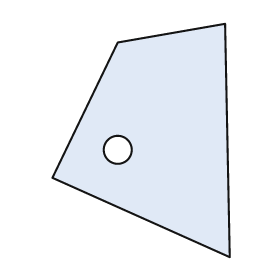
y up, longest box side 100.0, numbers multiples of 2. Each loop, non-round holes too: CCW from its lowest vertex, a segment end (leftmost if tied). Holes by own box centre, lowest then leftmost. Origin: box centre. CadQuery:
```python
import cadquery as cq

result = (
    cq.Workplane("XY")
    .moveTo(38.0, -50.0)
    .lineTo(36.0, 50.0)
    .lineTo(-10.0, 42.0)
    .lineTo(-38.0, -16.0)
    .close()
    .moveTo(-10.0, -4.0)
    .circle(6.0)
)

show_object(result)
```